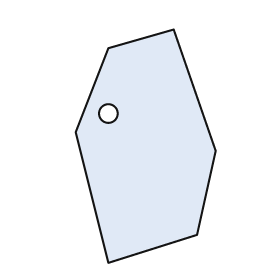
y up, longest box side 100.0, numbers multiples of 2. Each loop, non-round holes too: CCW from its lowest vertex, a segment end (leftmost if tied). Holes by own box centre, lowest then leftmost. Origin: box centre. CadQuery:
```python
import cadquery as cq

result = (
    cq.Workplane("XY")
    .moveTo(-16.0, -50.0)
    .lineTo(22.0, -38.0)
    .lineTo(30.0, -2.0)
    .lineTo(12.0, 50.0)
    .lineTo(-16.0, 42.0)
    .lineTo(-30.0, 6.0)
    .close()
    .moveTo(-16.0, 14.0)
    .circle(4.0)
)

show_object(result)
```